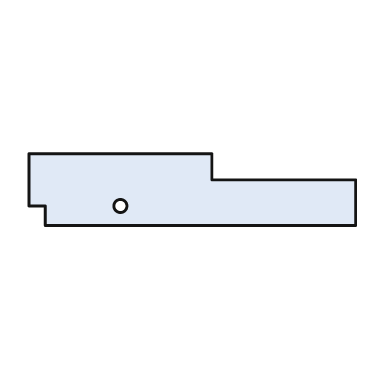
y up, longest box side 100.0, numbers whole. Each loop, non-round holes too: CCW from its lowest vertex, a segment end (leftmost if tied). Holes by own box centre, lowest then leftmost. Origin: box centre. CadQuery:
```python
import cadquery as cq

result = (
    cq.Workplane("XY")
    .moveTo(-45.0, -11.0)
    .lineTo(50.0, -11.0)
    .lineTo(50.0, 3.0)
    .lineTo(6.0, 3.0)
    .lineTo(6.0, 11.0)
    .lineTo(-50.0, 11.0)
    .lineTo(-50.0, -5.0)
    .lineTo(-45.0, -5.0)
    .close()
    .moveTo(-22.0, -5.0)
    .circle(2.0)
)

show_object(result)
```